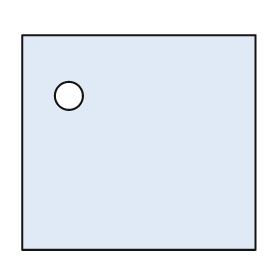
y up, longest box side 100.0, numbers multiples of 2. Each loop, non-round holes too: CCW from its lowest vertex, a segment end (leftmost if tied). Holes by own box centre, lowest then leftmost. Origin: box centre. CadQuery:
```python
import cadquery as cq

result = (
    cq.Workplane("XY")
    .moveTo(-50.0, -46.0)
    .lineTo(50.0, -46.0)
    .lineTo(50.0, 46.0)
    .lineTo(-50.0, 46.0)
    .close()
    .moveTo(-30.0, 20.0)
    .circle(6.0)
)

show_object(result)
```